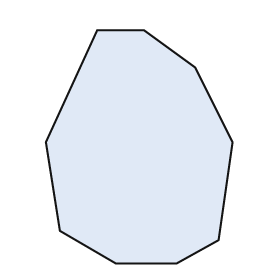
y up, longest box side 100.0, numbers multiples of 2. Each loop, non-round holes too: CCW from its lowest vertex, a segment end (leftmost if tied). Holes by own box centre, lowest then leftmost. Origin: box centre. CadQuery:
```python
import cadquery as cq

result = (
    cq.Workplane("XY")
    .moveTo(-10.0, -50.0)
    .lineTo(16.0, -50.0)
    .lineTo(34.0, -40.0)
    .lineTo(40.0, 2.0)
    .lineTo(24.0, 34.0)
    .lineTo(2.0, 50.0)
    .lineTo(-18.0, 50.0)
    .lineTo(-40.0, 2.0)
    .lineTo(-34.0, -36.0)
    .close()
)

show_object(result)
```